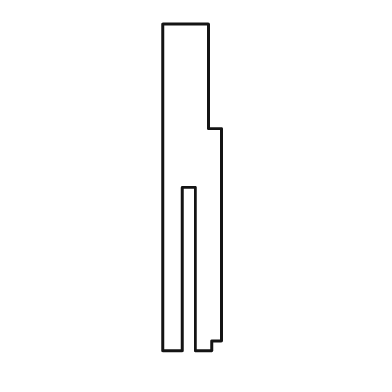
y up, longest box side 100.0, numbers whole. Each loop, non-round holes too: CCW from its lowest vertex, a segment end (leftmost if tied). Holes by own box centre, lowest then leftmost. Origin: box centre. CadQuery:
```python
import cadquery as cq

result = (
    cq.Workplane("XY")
    .moveTo(-9.0, -50.0)
    .lineTo(-3.0, -50.0)
    .lineTo(-3.0, 0.0)
    .lineTo(1.0, 0.0)
    .lineTo(1.0, -50.0)
    .lineTo(6.0, -50.0)
    .lineTo(6.0, -47.0)
    .lineTo(9.0, -47.0)
    .lineTo(9.0, 18.0)
    .lineTo(5.0, 18.0)
    .lineTo(5.0, 50.0)
    .lineTo(-9.0, 50.0)
    .close()
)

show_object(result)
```